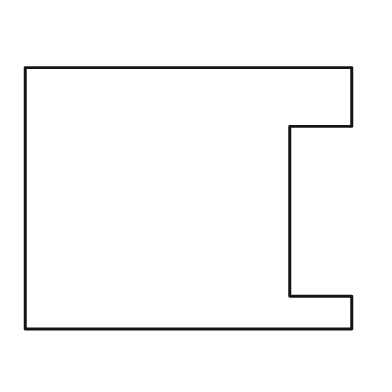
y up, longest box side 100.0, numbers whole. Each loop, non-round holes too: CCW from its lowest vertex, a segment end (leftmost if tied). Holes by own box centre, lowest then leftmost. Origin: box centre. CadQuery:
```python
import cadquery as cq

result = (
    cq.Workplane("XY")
    .moveTo(-50.0, -40.0)
    .lineTo(50.0, -40.0)
    .lineTo(50.0, -30.0)
    .lineTo(31.0, -30.0)
    .lineTo(31.0, 22.0)
    .lineTo(50.0, 22.0)
    .lineTo(50.0, 40.0)
    .lineTo(-50.0, 40.0)
    .close()
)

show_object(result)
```